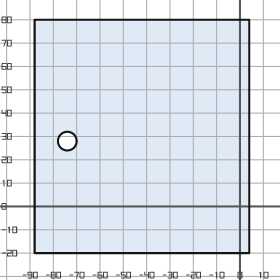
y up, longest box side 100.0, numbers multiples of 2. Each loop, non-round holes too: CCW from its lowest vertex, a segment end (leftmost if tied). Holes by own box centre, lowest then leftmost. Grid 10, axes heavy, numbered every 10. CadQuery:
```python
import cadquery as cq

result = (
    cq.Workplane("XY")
    .moveTo(-88.0, -20.0)
    .lineTo(4.0, -20.0)
    .lineTo(4.0, 80.0)
    .lineTo(-88.0, 80.0)
    .close()
    .moveTo(-74.0, 28.0)
    .circle(4.0)
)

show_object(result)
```